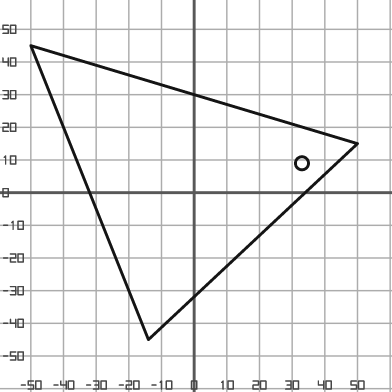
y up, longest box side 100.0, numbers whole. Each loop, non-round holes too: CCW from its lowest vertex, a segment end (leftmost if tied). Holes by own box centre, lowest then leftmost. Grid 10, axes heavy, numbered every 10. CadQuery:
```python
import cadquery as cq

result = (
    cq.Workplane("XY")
    .moveTo(-14.0, -45.0)
    .lineTo(50.0, 15.0)
    .lineTo(-50.0, 45.0)
    .close()
    .moveTo(33.0, 9.0)
    .circle(2.0)
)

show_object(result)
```